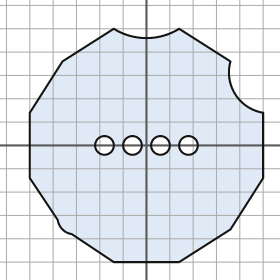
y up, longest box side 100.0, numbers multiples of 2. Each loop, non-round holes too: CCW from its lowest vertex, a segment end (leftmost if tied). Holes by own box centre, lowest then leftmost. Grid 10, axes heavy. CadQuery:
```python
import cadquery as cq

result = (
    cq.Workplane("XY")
    .moveTo(-14.0, -50.0)
    .lineTo(14.0, -50.0)
    .lineTo(36.0, -36.0)
    .lineTo(50.0, -14.0)
    .lineTo(50.0, 14.0)
    .threePointArc((38.0, 22.0), (36.0, 36.0))
    .lineTo(14.0, 50.0)
    .threePointArc((0.0, 46.0), (-14.0, 50.0))
    .lineTo(-36.0, 36.0)
    .lineTo(-50.0, 14.0)
    .lineTo(-50.0, -14.0)
    .lineTo(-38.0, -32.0)
    .threePointArc((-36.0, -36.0), (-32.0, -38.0))
    .close()
    .moveTo(-18.0, 0.0)
    .circle(4.0)
    .moveTo(-6.0, 0.0)
    .circle(4.0)
    .moveTo(6.0, 0.0)
    .circle(4.0)
    .moveTo(18.0, 0.0)
    .circle(4.0)
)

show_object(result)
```